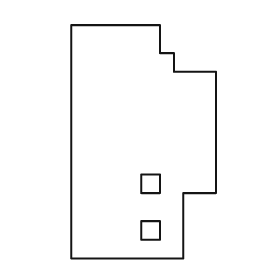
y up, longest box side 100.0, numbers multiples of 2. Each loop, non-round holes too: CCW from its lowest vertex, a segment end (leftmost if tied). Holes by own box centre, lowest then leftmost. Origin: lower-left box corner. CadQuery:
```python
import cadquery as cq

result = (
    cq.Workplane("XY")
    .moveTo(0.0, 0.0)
    .lineTo(48.0, 0.0)
    .lineTo(48.0, 28.0)
    .lineTo(62.0, 28.0)
    .lineTo(62.0, 80.0)
    .lineTo(44.0, 80.0)
    .lineTo(44.0, 88.0)
    .lineTo(38.0, 88.0)
    .lineTo(38.0, 100.0)
    .lineTo(0.0, 100.0)
    .close()
    .moveTo(30.0, 8.0)
    .lineTo(38.0, 8.0)
    .lineTo(38.0, 16.0)
    .lineTo(30.0, 16.0)
    .close()
    .moveTo(30.0, 28.0)
    .lineTo(38.0, 28.0)
    .lineTo(38.0, 36.0)
    .lineTo(30.0, 36.0)
    .close()
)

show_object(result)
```